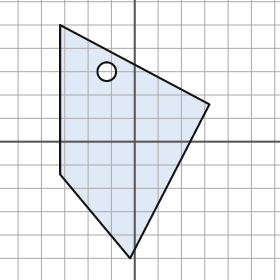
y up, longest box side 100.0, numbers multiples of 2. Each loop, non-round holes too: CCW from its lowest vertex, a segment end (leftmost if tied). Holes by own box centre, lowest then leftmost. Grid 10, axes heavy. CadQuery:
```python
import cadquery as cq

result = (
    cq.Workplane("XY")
    .moveTo(-2.0, -50.0)
    .lineTo(32.0, 16.0)
    .lineTo(-32.0, 50.0)
    .lineTo(-32.0, -14.0)
    .close()
    .moveTo(-12.0, 30.0)
    .circle(4.0)
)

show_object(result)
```